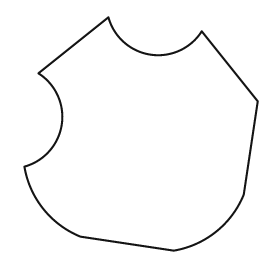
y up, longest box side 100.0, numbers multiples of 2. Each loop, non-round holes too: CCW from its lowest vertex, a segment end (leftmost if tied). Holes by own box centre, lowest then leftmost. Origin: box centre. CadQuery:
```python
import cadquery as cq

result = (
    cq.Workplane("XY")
    .moveTo(14.0, -50.0)
    .threePointArc((32.0, -42.0), (44.0, -26.0))
    .lineTo(50.0, 14.0)
    .lineTo(26.0, 44.0)
    .threePointArc((4.0, 34.0), (-14.0, 50.0))
    .lineTo(-44.0, 26.0)
    .threePointArc((-34.0, 4.0), (-50.0, -14.0))
    .threePointArc((-42.0, -32.0), (-26.0, -44.0))
    .close()
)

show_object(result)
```